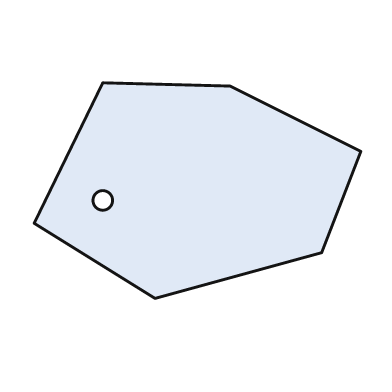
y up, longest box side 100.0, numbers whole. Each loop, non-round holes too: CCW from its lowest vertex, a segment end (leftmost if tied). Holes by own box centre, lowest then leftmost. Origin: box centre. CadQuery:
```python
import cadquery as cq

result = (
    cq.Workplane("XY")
    .moveTo(-13.0, -33.0)
    .lineTo(38.0, -19.0)
    .lineTo(50.0, 12.0)
    .lineTo(10.0, 32.0)
    .lineTo(-29.0, 33.0)
    .lineTo(-50.0, -10.0)
    .close()
    .moveTo(-29.0, -3.0)
    .circle(3.0)
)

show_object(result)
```